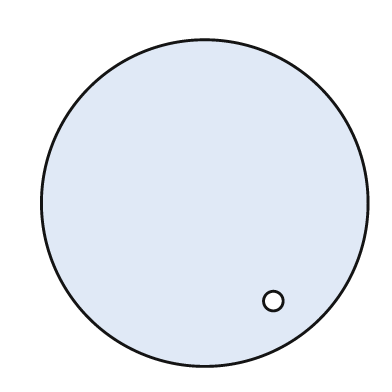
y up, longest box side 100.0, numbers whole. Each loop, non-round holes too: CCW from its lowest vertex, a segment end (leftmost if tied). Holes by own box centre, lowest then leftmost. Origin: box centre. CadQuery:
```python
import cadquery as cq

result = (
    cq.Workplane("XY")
    .moveTo(0.0, 0.0)
    .circle(50.0)
    .moveTo(21.0, -30.0)
    .circle(3.0)
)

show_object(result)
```